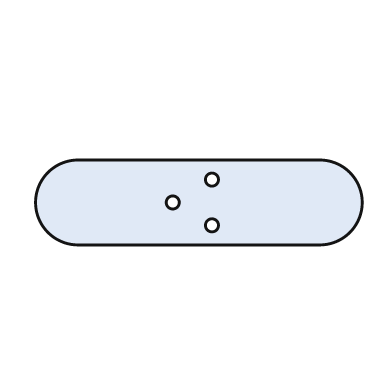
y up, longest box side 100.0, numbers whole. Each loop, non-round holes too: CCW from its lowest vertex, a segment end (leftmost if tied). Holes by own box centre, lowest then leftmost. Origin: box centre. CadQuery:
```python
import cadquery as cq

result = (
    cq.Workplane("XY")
    .moveTo(-37.0, -13.0)
    .lineTo(37.0, -13.0)
    .threePointArc((50.0, 0.0), (37.0, 13.0))
    .lineTo(-37.0, 13.0)
    .threePointArc((-50.0, 0.0), (-37.0, -13.0))
    .close()
    .moveTo(4.0, -7.0)
    .circle(2.0)
    .moveTo(-8.0, 0.0)
    .circle(2.0)
    .moveTo(4.0, 7.0)
    .circle(2.0)
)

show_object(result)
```